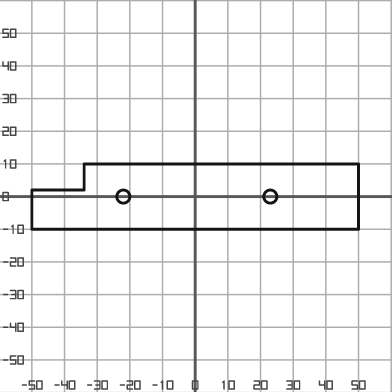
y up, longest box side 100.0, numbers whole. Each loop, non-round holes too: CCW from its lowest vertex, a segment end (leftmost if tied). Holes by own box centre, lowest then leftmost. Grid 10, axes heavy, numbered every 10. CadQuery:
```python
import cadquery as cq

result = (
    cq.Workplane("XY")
    .moveTo(-50.0, -10.0)
    .lineTo(50.0, -10.0)
    .lineTo(50.0, 10.0)
    .lineTo(-34.0, 10.0)
    .lineTo(-34.0, 2.0)
    .lineTo(-50.0, 2.0)
    .close()
    .moveTo(-22.0, 0.0)
    .circle(2.0)
    .moveTo(23.0, 0.0)
    .circle(2.0)
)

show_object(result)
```